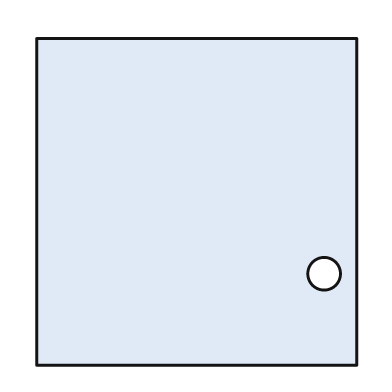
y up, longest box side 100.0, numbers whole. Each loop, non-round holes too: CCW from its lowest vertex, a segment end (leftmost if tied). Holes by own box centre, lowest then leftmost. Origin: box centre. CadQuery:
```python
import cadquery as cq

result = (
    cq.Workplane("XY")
    .moveTo(-49.0, -50.0)
    .lineTo(49.0, -50.0)
    .lineTo(49.0, 50.0)
    .lineTo(-49.0, 50.0)
    .close()
    .moveTo(39.0, -22.0)
    .circle(5.0)
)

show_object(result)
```